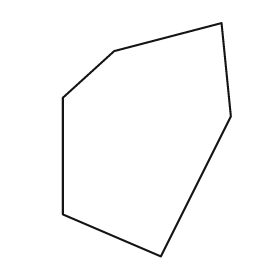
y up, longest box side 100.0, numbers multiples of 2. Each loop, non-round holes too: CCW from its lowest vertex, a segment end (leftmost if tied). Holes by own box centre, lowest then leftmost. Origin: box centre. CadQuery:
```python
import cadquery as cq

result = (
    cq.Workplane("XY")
    .moveTo(6.0, -50.0)
    .lineTo(36.0, 10.0)
    .lineTo(32.0, 50.0)
    .lineTo(-14.0, 38.0)
    .lineTo(-36.0, 18.0)
    .lineTo(-36.0, -32.0)
    .close()
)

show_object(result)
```